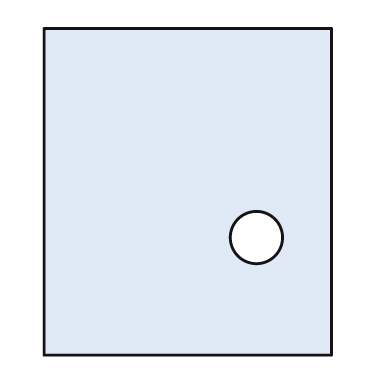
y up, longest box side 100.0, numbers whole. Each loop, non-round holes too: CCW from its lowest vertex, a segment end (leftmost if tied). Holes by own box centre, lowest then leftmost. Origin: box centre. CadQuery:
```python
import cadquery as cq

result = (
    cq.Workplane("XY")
    .moveTo(-44.0, -50.0)
    .lineTo(44.0, -50.0)
    .lineTo(44.0, 50.0)
    .lineTo(-44.0, 50.0)
    .close()
    .moveTo(21.0, -14.0)
    .circle(8.0)
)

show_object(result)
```